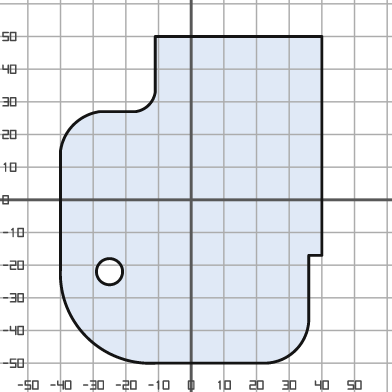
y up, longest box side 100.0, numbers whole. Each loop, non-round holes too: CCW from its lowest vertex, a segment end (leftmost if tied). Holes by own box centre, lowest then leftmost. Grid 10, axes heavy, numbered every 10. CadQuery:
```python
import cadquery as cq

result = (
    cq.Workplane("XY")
    .moveTo(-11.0, -50.0)
    .lineTo(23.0, -50.0)
    .threePointArc((32.0, -46.0), (36.0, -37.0))
    .lineTo(36.0, -17.0)
    .lineTo(40.0, -17.0)
    .lineTo(40.0, 50.0)
    .lineTo(-11.0, 50.0)
    .lineTo(-11.0, 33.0)
    .threePointArc((-13.0, 29.0), (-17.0, 27.0))
    .lineTo(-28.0, 27.0)
    .threePointArc((-36.0, 23.0), (-40.0, 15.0))
    .lineTo(-40.0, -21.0)
    .threePointArc((-32.0, -42.0), (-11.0, -50.0))
    .close()
    .moveTo(-25.0, -22.0)
    .circle(4.0)
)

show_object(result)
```